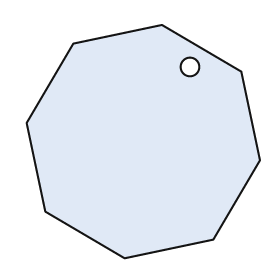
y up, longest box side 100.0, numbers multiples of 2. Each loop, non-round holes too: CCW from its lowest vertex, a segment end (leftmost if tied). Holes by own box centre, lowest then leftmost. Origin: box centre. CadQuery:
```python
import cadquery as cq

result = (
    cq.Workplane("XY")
    .moveTo(-8.0, -50.0)
    .lineTo(30.0, -42.0)
    .lineTo(50.0, -8.0)
    .lineTo(42.0, 30.0)
    .lineTo(8.0, 50.0)
    .lineTo(-30.0, 42.0)
    .lineTo(-50.0, 8.0)
    .lineTo(-42.0, -30.0)
    .close()
    .moveTo(20.0, 32.0)
    .circle(4.0)
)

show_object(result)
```